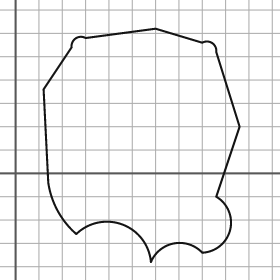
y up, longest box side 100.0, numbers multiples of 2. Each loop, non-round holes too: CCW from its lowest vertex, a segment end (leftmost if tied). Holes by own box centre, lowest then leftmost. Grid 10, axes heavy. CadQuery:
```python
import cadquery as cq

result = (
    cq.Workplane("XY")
    .moveTo(58.0, -38.0)
    .threePointArc((68.0, -30.0), (80.0, -34.0))
    .threePointArc((92.0, -24.0), (86.0, -10.0))
    .lineTo(96.0, 20.0)
    .lineTo(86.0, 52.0)
    .threePointArc((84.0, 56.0), (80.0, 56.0))
    .lineTo(60.0, 62.0)
    .lineTo(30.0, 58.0)
    .threePointArc((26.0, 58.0), (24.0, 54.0))
    .lineTo(12.0, 36.0)
    .lineTo(14.0, -4.0)
    .threePointArc((18.0, -16.0), (26.0, -26.0))
    .threePointArc((46.0, -22.0), (58.0, -38.0))
    .close()
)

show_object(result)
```